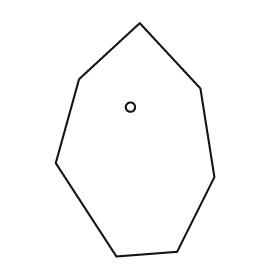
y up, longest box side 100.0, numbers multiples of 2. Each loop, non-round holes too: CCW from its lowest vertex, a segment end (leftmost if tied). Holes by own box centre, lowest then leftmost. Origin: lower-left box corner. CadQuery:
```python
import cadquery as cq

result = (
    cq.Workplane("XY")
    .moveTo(26.0, 0.0)
    .lineTo(52.0, 2.0)
    .lineTo(68.0, 34.0)
    .lineTo(62.0, 72.0)
    .lineTo(36.0, 100.0)
    .lineTo(10.0, 76.0)
    .lineTo(0.0, 40.0)
    .close()
    .moveTo(32.0, 64.0)
    .circle(2.0)
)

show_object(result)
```